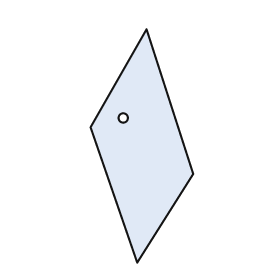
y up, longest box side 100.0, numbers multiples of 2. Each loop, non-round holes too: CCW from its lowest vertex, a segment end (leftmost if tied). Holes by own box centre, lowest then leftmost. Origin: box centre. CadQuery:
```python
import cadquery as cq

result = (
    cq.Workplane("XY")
    .moveTo(-2.0, -50.0)
    .lineTo(22.0, -12.0)
    .lineTo(2.0, 50.0)
    .lineTo(-22.0, 8.0)
    .close()
    .moveTo(-8.0, 12.0)
    .circle(2.0)
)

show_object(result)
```